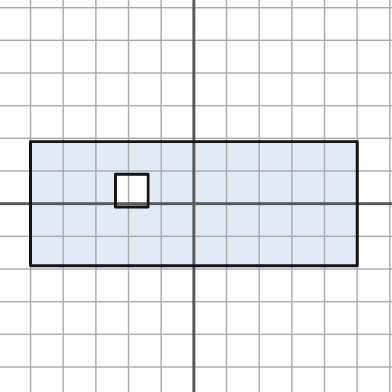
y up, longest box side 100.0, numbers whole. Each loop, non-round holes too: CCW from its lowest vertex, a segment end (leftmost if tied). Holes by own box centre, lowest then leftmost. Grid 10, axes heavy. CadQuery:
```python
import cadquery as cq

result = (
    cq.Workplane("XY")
    .moveTo(-50.0, -19.0)
    .lineTo(50.0, -19.0)
    .lineTo(50.0, 19.0)
    .lineTo(-50.0, 19.0)
    .close()
    .moveTo(-24.0, -1.0)
    .lineTo(-14.0, -1.0)
    .lineTo(-14.0, 9.0)
    .lineTo(-24.0, 9.0)
    .close()
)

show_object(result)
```